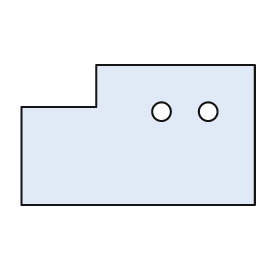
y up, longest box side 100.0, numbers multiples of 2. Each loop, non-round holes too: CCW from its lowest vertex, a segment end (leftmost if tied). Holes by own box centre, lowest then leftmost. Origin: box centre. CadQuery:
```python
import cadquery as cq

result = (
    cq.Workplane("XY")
    .moveTo(-50.0, -30.0)
    .lineTo(50.0, -30.0)
    .lineTo(50.0, 30.0)
    .lineTo(-18.0, 30.0)
    .lineTo(-18.0, 12.0)
    .lineTo(-50.0, 12.0)
    .close()
    .moveTo(10.0, 10.0)
    .circle(4.0)
    .moveTo(30.0, 10.0)
    .circle(4.0)
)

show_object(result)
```